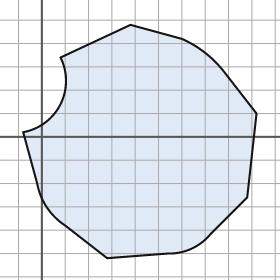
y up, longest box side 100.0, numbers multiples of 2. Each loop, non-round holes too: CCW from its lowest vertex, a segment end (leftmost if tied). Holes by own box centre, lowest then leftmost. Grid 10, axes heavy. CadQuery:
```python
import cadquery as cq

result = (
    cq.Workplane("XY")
    .moveTo(28.0, -52.0)
    .lineTo(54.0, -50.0)
    .threePointArc((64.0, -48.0), (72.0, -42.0))
    .lineTo(88.0, -26.0)
    .lineTo(92.0, 10.0)
    .lineTo(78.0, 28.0)
    .threePointArc((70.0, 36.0), (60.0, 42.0))
    .lineTo(38.0, 48.0)
    .lineTo(8.0, 34.0)
    .threePointArc((8.0, 14.0), (-8.0, 2.0))
    .lineTo(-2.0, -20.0)
    .threePointArc((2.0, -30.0), (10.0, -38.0))
    .close()
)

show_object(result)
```